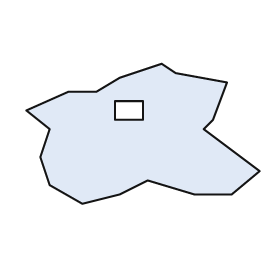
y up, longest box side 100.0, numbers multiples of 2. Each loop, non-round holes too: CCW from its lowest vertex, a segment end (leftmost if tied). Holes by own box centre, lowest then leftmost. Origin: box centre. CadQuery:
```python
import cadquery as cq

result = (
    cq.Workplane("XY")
    .moveTo(-26.0, -30.0)
    .lineTo(-10.0, -26.0)
    .lineTo(2.0, -20.0)
    .lineTo(22.0, -26.0)
    .lineTo(38.0, -26.0)
    .lineTo(50.0, -16.0)
    .lineTo(26.0, 2.0)
    .lineTo(30.0, 6.0)
    .lineTo(36.0, 22.0)
    .lineTo(14.0, 26.0)
    .lineTo(8.0, 30.0)
    .lineTo(-10.0, 24.0)
    .lineTo(-20.0, 18.0)
    .lineTo(-32.0, 18.0)
    .lineTo(-50.0, 10.0)
    .lineTo(-40.0, 2.0)
    .lineTo(-44.0, -10.0)
    .lineTo(-40.0, -22.0)
    .close()
    .moveTo(-12.0, 6.0)
    .lineTo(0.0, 6.0)
    .lineTo(0.0, 14.0)
    .lineTo(-12.0, 14.0)
    .close()
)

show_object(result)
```